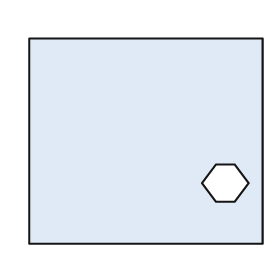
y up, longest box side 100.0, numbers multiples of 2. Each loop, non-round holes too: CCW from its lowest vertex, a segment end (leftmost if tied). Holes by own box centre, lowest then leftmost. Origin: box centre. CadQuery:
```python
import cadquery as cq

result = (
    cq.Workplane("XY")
    .moveTo(-50.0, -44.0)
    .lineTo(50.0, -44.0)
    .lineTo(50.0, 44.0)
    .lineTo(-50.0, 44.0)
    .close()
    .moveTo(30.0, -26.0)
    .lineTo(38.0, -26.0)
    .lineTo(44.0, -18.0)
    .lineTo(38.0, -10.0)
    .lineTo(30.0, -10.0)
    .lineTo(24.0, -18.0)
    .close()
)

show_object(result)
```